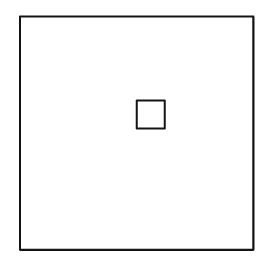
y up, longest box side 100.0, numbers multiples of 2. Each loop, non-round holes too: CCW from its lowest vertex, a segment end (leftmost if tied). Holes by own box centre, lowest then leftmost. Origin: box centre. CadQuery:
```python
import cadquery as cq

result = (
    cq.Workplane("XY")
    .moveTo(-50.0, -50.0)
    .lineTo(50.0, -50.0)
    .lineTo(50.0, 50.0)
    .lineTo(-50.0, 50.0)
    .close()
    .moveTo(0.0, 2.0)
    .lineTo(12.0, 2.0)
    .lineTo(12.0, 14.0)
    .lineTo(0.0, 14.0)
    .close()
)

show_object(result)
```